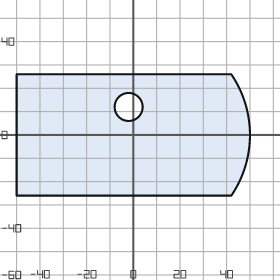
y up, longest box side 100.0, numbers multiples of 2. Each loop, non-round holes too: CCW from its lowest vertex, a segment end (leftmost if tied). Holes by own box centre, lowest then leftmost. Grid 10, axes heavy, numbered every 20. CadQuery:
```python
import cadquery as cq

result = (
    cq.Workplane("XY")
    .moveTo(-50.0, -26.0)
    .lineTo(42.0, -26.0)
    .threePointArc((50.0, 0.0), (42.0, 26.0))
    .lineTo(-50.0, 26.0)
    .close()
    .moveTo(-2.0, 12.0)
    .circle(6.0)
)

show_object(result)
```